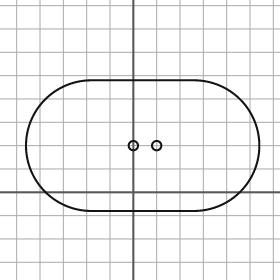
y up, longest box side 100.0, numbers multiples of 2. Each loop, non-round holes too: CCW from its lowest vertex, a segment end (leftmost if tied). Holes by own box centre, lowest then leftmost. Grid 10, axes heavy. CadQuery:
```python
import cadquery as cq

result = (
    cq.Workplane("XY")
    .moveTo(-18.0, -8.0)
    .lineTo(26.0, -8.0)
    .threePointArc((54.0, 20.0), (26.0, 48.0))
    .lineTo(-18.0, 48.0)
    .threePointArc((-46.0, 20.0), (-18.0, -8.0))
    .close()
    .moveTo(0.0, 20.0)
    .circle(2.0)
    .moveTo(10.0, 20.0)
    .circle(2.0)
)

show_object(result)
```